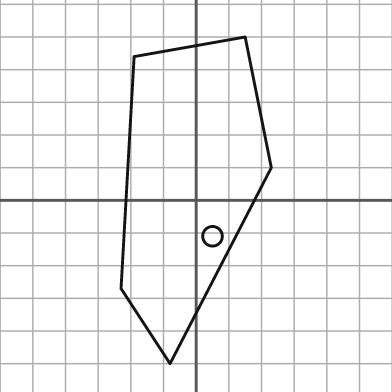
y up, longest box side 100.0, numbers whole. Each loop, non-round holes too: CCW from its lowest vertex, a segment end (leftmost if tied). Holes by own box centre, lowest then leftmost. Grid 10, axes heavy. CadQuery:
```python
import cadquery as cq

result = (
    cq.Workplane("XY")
    .moveTo(-8.0, -50.0)
    .lineTo(23.0, 10.0)
    .lineTo(15.0, 50.0)
    .lineTo(-19.0, 44.0)
    .lineTo(-23.0, -27.0)
    .close()
    .moveTo(5.0, -11.0)
    .circle(3.0)
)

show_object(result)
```